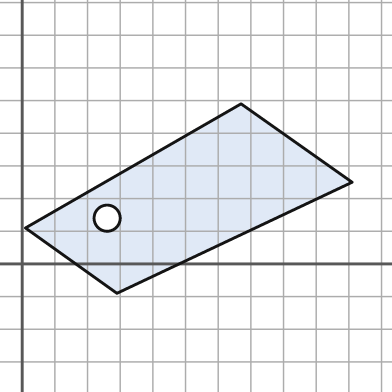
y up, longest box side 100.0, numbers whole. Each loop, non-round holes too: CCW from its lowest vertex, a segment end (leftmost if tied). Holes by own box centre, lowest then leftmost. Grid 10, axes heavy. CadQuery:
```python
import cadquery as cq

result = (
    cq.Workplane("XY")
    .moveTo(29.0, -9.0)
    .lineTo(101.0, 25.0)
    .lineTo(67.0, 49.0)
    .lineTo(1.0, 11.0)
    .close()
    .moveTo(26.0, 14.0)
    .circle(4.0)
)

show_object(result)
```